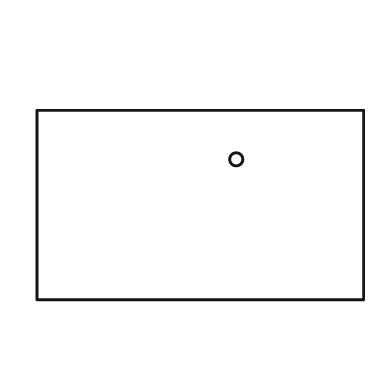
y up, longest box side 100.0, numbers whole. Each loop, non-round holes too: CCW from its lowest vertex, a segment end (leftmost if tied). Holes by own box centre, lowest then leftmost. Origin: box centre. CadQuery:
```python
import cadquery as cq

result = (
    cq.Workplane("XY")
    .moveTo(-50.0, -29.0)
    .lineTo(50.0, -29.0)
    .lineTo(50.0, 29.0)
    .lineTo(-50.0, 29.0)
    .close()
    .moveTo(11.0, 14.0)
    .circle(2.0)
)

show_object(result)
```